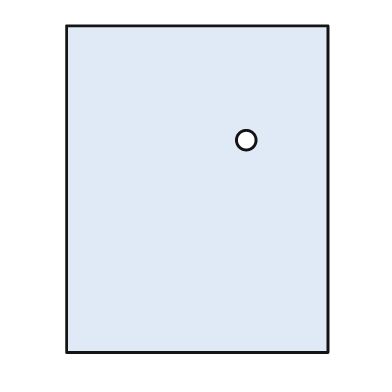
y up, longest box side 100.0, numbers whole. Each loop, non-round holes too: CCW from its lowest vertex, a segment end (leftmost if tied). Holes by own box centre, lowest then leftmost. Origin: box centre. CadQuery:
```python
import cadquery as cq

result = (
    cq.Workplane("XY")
    .moveTo(-40.0, -50.0)
    .lineTo(40.0, -50.0)
    .lineTo(40.0, 50.0)
    .lineTo(-40.0, 50.0)
    .close()
    .moveTo(15.0, 15.0)
    .circle(3.0)
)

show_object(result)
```